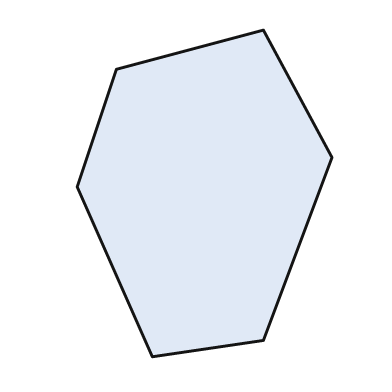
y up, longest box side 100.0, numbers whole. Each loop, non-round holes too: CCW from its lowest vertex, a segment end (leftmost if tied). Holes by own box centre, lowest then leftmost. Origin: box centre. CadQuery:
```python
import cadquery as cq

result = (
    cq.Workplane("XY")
    .moveTo(-16.0, -50.0)
    .lineTo(18.0, -45.0)
    .lineTo(39.0, 11.0)
    .lineTo(18.0, 50.0)
    .lineTo(-27.0, 38.0)
    .lineTo(-39.0, 2.0)
    .close()
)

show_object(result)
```